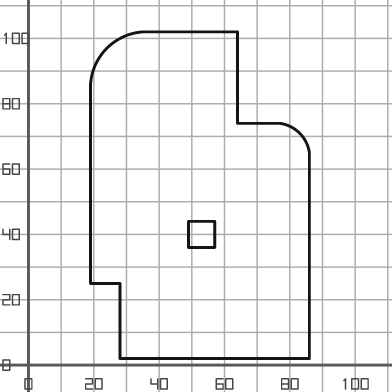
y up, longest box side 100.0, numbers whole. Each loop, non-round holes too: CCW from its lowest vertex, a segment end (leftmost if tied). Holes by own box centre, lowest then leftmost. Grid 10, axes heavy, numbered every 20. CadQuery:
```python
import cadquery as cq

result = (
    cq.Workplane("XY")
    .moveTo(28.0, 2.0)
    .lineTo(86.0, 2.0)
    .lineTo(86.0, 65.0)
    .threePointArc((83.0, 71.0), (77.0, 74.0))
    .lineTo(64.0, 74.0)
    .lineTo(64.0, 102.0)
    .lineTo(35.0, 102.0)
    .threePointArc((24.0, 97.0), (19.0, 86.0))
    .lineTo(19.0, 25.0)
    .lineTo(28.0, 25.0)
    .close()
    .moveTo(49.0, 36.0)
    .lineTo(57.0, 36.0)
    .lineTo(57.0, 44.0)
    .lineTo(49.0, 44.0)
    .close()
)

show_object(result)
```